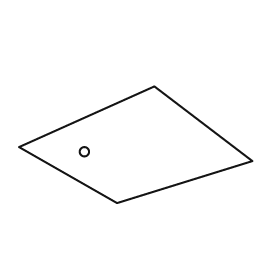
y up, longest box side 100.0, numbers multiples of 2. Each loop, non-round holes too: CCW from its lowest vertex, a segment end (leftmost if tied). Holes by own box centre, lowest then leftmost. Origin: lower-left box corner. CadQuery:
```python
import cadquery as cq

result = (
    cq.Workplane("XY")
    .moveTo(42.0, 0.0)
    .lineTo(100.0, 18.0)
    .lineTo(58.0, 50.0)
    .lineTo(0.0, 24.0)
    .close()
    .moveTo(28.0, 22.0)
    .circle(2.0)
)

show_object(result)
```